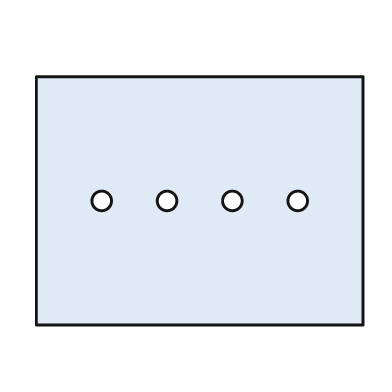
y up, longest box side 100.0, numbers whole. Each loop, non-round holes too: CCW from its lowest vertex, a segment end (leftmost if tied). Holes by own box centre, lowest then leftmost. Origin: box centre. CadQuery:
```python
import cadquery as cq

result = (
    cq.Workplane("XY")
    .moveTo(-50.0, -38.0)
    .lineTo(50.0, -38.0)
    .lineTo(50.0, 38.0)
    .lineTo(-50.0, 38.0)
    .close()
    .moveTo(-30.0, 0.0)
    .circle(3.0)
    .moveTo(-10.0, 0.0)
    .circle(3.0)
    .moveTo(10.0, 0.0)
    .circle(3.0)
    .moveTo(30.0, 0.0)
    .circle(3.0)
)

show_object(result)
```